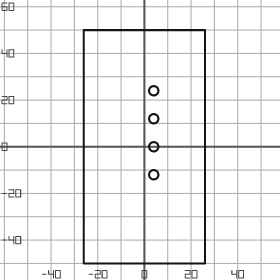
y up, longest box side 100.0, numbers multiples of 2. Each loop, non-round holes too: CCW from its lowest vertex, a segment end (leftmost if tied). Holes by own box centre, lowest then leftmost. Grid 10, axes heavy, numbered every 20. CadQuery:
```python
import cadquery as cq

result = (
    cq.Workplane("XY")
    .moveTo(-26.0, -50.0)
    .lineTo(26.0, -50.0)
    .lineTo(26.0, 50.0)
    .lineTo(-26.0, 50.0)
    .close()
    .moveTo(4.0, -12.0)
    .circle(2.0)
    .moveTo(4.0, 0.0)
    .circle(2.0)
    .moveTo(4.0, 12.0)
    .circle(2.0)
    .moveTo(4.0, 24.0)
    .circle(2.0)
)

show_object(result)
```